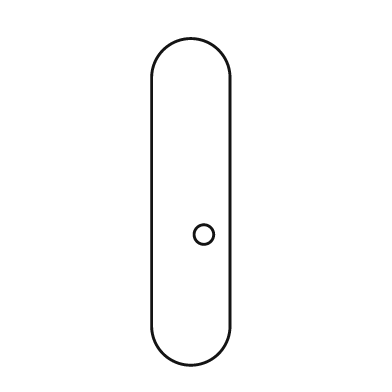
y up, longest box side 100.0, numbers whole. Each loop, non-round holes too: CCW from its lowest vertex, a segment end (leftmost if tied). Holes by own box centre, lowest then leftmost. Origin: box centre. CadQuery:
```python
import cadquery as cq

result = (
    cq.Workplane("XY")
    .moveTo(-12.0, -38.0)
    .threePointArc((0.0, -50.0), (12.0, -38.0))
    .lineTo(12.0, 38.0)
    .threePointArc((0.0, 50.0), (-12.0, 38.0))
    .close()
    .moveTo(4.0, -10.0)
    .circle(3.0)
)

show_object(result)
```